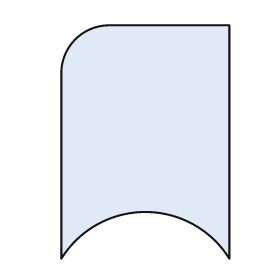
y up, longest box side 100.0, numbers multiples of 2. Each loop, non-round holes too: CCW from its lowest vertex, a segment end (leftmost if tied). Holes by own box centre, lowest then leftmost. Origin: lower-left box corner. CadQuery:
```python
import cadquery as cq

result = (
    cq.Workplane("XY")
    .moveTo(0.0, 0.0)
    .threePointArc((36.0, 20.0), (72.0, 0.0))
    .lineTo(72.0, 100.0)
    .lineTo(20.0, 100.0)
    .threePointArc((6.0, 94.0), (0.0, 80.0))
    .close()
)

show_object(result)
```